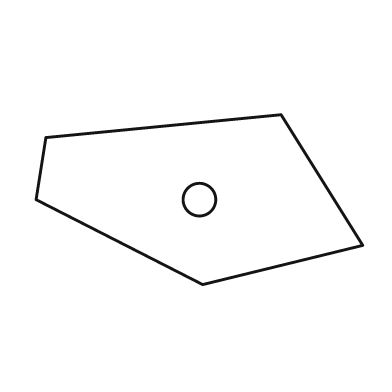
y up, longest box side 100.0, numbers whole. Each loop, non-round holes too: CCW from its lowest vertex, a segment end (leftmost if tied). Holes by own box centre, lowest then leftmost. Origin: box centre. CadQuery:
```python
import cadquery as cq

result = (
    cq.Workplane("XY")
    .moveTo(1.0, -26.0)
    .lineTo(50.0, -14.0)
    .lineTo(25.0, 26.0)
    .lineTo(-47.0, 19.0)
    .lineTo(-50.0, 0.0)
    .close()
    .moveTo(0.0, 0.0)
    .circle(5.0)
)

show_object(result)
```